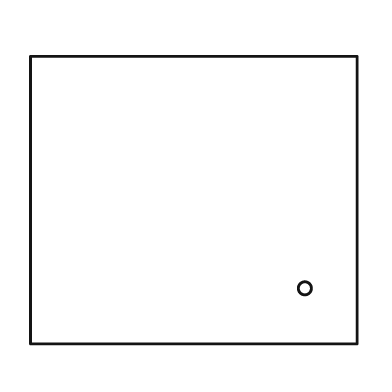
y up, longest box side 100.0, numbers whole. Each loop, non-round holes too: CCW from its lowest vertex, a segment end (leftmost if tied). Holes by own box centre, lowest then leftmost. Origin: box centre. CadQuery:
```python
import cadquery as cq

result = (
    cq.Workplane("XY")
    .moveTo(-50.0, -44.0)
    .lineTo(50.0, -44.0)
    .lineTo(50.0, 44.0)
    .lineTo(-50.0, 44.0)
    .close()
    .moveTo(34.0, -27.0)
    .circle(2.0)
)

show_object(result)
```